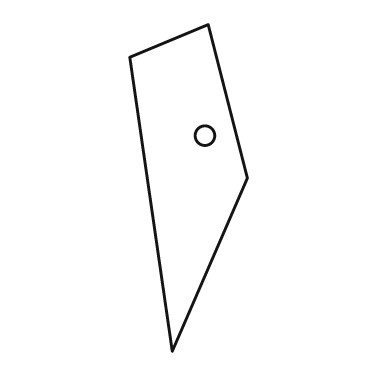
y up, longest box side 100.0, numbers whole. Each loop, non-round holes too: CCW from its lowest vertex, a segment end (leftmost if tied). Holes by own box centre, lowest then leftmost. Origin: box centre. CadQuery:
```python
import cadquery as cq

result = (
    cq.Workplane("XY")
    .moveTo(-5.0, -50.0)
    .lineTo(18.0, 3.0)
    .lineTo(6.0, 50.0)
    .lineTo(-18.0, 40.0)
    .close()
    .moveTo(5.0, 16.0)
    .circle(3.0)
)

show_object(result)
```